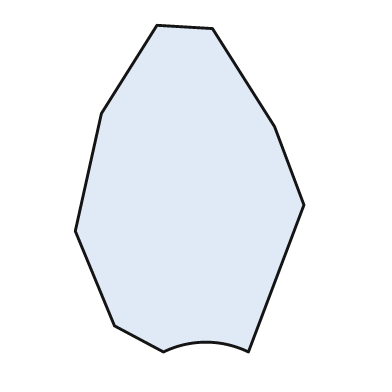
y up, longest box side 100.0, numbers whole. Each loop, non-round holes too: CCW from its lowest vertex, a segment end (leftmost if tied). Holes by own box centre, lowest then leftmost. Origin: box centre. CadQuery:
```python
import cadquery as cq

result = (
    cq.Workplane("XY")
    .moveTo(-8.0, -50.0)
    .threePointArc((5.0, -47.0), (18.0, -50.0))
    .lineTo(35.0, -5.0)
    .lineTo(26.0, 19.0)
    .lineTo(7.0, 49.0)
    .lineTo(-10.0, 50.0)
    .lineTo(-27.0, 23.0)
    .lineTo(-35.0, -13.0)
    .lineTo(-23.0, -42.0)
    .close()
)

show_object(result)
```